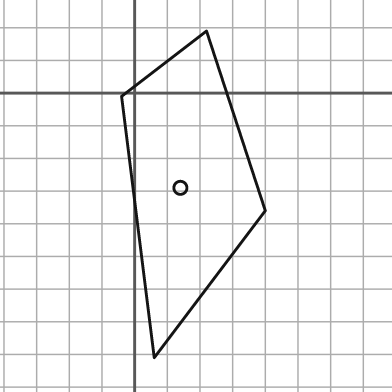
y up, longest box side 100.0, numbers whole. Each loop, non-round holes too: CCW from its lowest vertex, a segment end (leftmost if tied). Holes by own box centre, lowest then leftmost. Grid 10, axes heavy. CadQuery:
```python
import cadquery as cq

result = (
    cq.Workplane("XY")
    .moveTo(6.0, -81.0)
    .lineTo(40.0, -36.0)
    .lineTo(22.0, 19.0)
    .lineTo(-4.0, -1.0)
    .close()
    .moveTo(14.0, -29.0)
    .circle(2.0)
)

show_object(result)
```